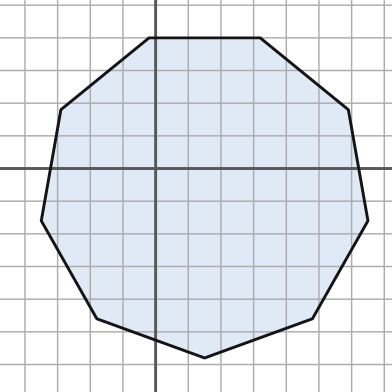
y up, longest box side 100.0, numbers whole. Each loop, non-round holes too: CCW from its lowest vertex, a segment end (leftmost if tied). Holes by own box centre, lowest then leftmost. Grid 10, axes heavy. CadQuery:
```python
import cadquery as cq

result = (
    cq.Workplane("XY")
    .moveTo(15.0, -58.0)
    .lineTo(48.0, -46.0)
    .lineTo(65.0, -16.0)
    .lineTo(59.0, 18.0)
    .lineTo(32.0, 40.0)
    .lineTo(-2.0, 40.0)
    .lineTo(-29.0, 18.0)
    .lineTo(-35.0, -16.0)
    .lineTo(-18.0, -46.0)
    .close()
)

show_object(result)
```